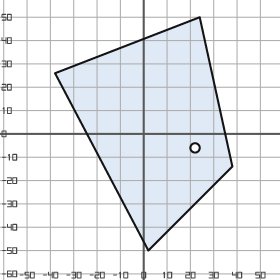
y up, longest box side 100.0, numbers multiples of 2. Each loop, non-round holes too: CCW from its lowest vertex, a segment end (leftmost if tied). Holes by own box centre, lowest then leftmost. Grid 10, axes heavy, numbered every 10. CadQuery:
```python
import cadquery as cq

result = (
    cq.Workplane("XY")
    .moveTo(2.0, -50.0)
    .lineTo(38.0, -14.0)
    .lineTo(24.0, 50.0)
    .lineTo(-38.0, 26.0)
    .close()
    .moveTo(22.0, -6.0)
    .circle(2.0)
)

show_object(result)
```